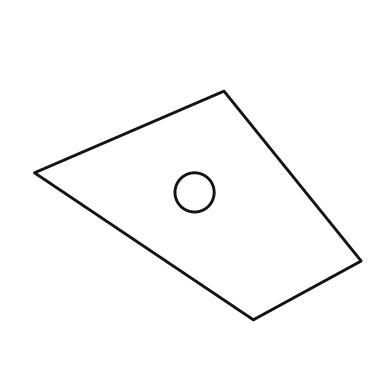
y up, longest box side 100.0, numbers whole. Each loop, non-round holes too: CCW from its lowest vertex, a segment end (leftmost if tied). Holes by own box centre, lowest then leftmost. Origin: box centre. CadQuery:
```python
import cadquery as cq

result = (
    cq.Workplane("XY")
    .moveTo(17.0, -35.0)
    .lineTo(50.0, -17.0)
    .lineTo(8.0, 35.0)
    .lineTo(-50.0, 10.0)
    .close()
    .moveTo(-1.0, 4.0)
    .circle(6.0)
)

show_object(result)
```